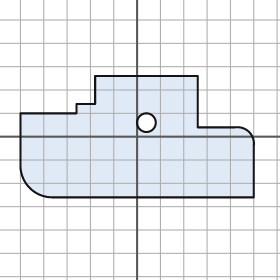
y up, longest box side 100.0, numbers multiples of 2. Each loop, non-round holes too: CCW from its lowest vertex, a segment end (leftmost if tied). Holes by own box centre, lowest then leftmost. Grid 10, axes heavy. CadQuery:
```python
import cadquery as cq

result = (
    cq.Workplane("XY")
    .moveTo(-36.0, -26.0)
    .lineTo(50.0, -26.0)
    .lineTo(50.0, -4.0)
    .threePointArc((48.0, 2.0), (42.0, 4.0))
    .lineTo(26.0, 4.0)
    .lineTo(26.0, 26.0)
    .lineTo(-18.0, 26.0)
    .lineTo(-18.0, 14.0)
    .lineTo(-26.0, 14.0)
    .lineTo(-26.0, 10.0)
    .lineTo(-50.0, 10.0)
    .lineTo(-50.0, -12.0)
    .threePointArc((-46.0, -22.0), (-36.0, -26.0))
    .close()
    .moveTo(4.0, 6.0)
    .circle(4.0)
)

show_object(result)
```